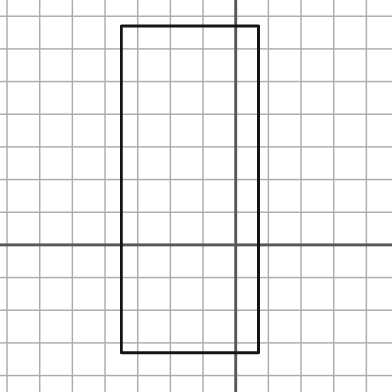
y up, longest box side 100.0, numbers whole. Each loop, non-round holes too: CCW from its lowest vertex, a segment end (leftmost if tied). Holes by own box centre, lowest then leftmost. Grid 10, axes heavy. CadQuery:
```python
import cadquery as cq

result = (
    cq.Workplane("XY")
    .moveTo(-35.0, -33.0)
    .lineTo(7.0, -33.0)
    .lineTo(7.0, 67.0)
    .lineTo(-35.0, 67.0)
    .close()
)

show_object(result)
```